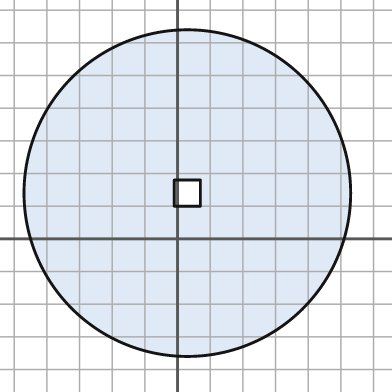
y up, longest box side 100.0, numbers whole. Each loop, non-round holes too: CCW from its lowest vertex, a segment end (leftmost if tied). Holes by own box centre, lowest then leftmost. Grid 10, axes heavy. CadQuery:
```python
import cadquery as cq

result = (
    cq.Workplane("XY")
    .moveTo(3.0, 14.0)
    .circle(50.0)
    .moveTo(-1.0, 10.0)
    .lineTo(7.0, 10.0)
    .lineTo(7.0, 18.0)
    .lineTo(-1.0, 18.0)
    .close()
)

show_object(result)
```